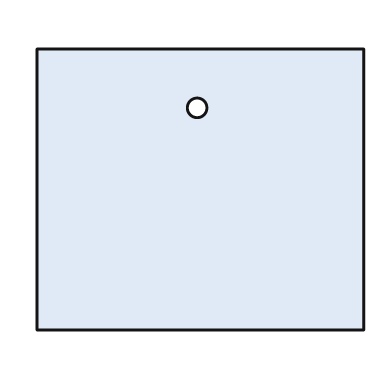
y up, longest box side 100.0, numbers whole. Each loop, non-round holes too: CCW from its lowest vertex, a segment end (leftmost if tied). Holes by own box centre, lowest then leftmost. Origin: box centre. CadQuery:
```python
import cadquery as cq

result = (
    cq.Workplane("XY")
    .moveTo(-50.0, -43.0)
    .lineTo(50.0, -43.0)
    .lineTo(50.0, 43.0)
    .lineTo(-50.0, 43.0)
    .close()
    .moveTo(-1.0, 25.0)
    .circle(3.0)
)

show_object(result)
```